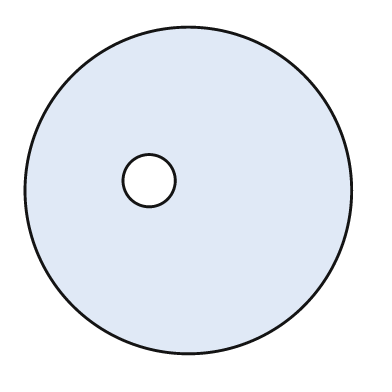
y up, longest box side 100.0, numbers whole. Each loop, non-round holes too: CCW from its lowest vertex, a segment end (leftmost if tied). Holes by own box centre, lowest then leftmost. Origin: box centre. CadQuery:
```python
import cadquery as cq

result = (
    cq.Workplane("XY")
    .moveTo(0.0, 0.0)
    .circle(50.0)
    .moveTo(-12.0, 3.0)
    .circle(8.0)
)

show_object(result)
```